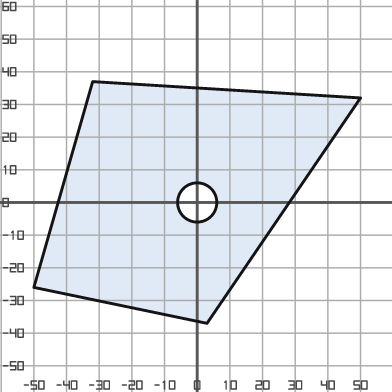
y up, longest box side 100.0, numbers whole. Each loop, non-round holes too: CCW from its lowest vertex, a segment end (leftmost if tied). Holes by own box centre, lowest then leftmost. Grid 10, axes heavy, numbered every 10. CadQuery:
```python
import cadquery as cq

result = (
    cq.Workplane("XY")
    .moveTo(3.0, -37.0)
    .lineTo(50.0, 32.0)
    .lineTo(-32.0, 37.0)
    .lineTo(-50.0, -26.0)
    .close()
    .moveTo(0.0, 0.0)
    .circle(6.0)
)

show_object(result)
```